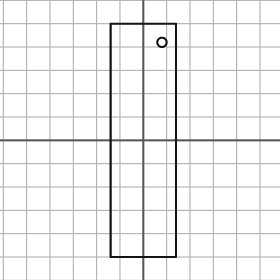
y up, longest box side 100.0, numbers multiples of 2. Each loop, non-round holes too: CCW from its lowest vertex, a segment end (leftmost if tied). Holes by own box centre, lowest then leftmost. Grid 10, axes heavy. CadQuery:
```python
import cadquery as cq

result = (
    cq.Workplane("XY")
    .moveTo(-14.0, -50.0)
    .lineTo(14.0, -50.0)
    .lineTo(14.0, 50.0)
    .lineTo(-14.0, 50.0)
    .close()
    .moveTo(8.0, 42.0)
    .circle(2.0)
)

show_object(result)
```